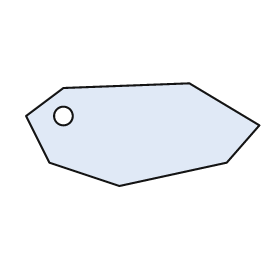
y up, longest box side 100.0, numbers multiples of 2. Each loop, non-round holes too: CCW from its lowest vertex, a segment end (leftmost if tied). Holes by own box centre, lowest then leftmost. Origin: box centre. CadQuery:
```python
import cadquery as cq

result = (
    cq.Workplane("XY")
    .moveTo(-10.0, -22.0)
    .lineTo(36.0, -12.0)
    .lineTo(50.0, 4.0)
    .lineTo(20.0, 22.0)
    .lineTo(-34.0, 20.0)
    .lineTo(-50.0, 8.0)
    .lineTo(-40.0, -12.0)
    .close()
    .moveTo(-34.0, 8.0)
    .circle(4.0)
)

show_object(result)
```